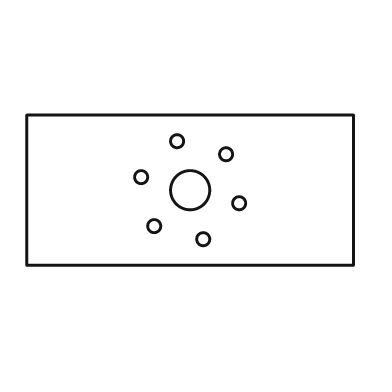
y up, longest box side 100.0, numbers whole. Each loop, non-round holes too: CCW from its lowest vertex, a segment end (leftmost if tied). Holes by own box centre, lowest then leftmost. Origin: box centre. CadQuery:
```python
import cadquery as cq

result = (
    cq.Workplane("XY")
    .moveTo(-50.0, -23.0)
    .lineTo(50.0, -23.0)
    .lineTo(50.0, 23.0)
    .lineTo(-50.0, 23.0)
    .close()
    .moveTo(4.0, -15.0)
    .circle(2.0)
    .moveTo(-11.0, -11.0)
    .circle(2.0)
    .moveTo(15.0, -4.0)
    .circle(2.0)
    .moveTo(0.0, 0.0)
    .circle(6.0)
    .moveTo(-15.0, 4.0)
    .circle(2.0)
    .moveTo(11.0, 11.0)
    .circle(2.0)
    .moveTo(-4.0, 15.0)
    .circle(2.0)
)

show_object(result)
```